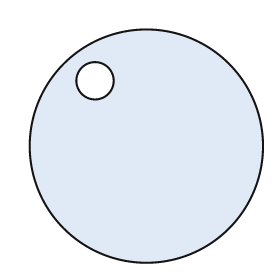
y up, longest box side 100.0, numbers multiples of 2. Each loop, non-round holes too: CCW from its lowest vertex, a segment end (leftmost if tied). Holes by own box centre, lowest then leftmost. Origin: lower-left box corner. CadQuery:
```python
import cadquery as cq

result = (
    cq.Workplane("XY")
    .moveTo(50.0, 50.0)
    .circle(50.0)
    .moveTo(28.0, 78.0)
    .circle(8.0)
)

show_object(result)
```